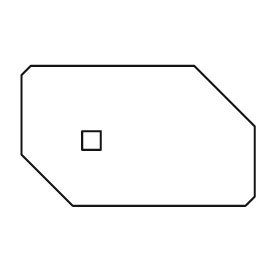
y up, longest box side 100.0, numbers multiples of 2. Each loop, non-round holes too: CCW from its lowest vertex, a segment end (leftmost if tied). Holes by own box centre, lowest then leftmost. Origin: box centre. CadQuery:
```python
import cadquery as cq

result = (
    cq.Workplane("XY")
    .moveTo(-28.0, -30.0)
    .lineTo(46.0, -30.0)
    .lineTo(50.0, -26.0)
    .lineTo(50.0, 4.0)
    .lineTo(24.0, 30.0)
    .lineTo(-46.0, 30.0)
    .lineTo(-50.0, 26.0)
    .lineTo(-50.0, -8.0)
    .close()
    .moveTo(-24.0, -6.0)
    .lineTo(-16.0, -6.0)
    .lineTo(-16.0, 2.0)
    .lineTo(-24.0, 2.0)
    .close()
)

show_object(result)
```